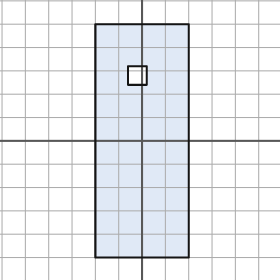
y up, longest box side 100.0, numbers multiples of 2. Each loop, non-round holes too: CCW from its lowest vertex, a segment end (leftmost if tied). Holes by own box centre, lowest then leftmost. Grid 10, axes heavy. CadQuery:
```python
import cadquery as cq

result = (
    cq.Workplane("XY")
    .moveTo(-20.0, -50.0)
    .lineTo(20.0, -50.0)
    .lineTo(20.0, 50.0)
    .lineTo(-20.0, 50.0)
    .close()
    .moveTo(-6.0, 24.0)
    .lineTo(2.0, 24.0)
    .lineTo(2.0, 32.0)
    .lineTo(-6.0, 32.0)
    .close()
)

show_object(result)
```